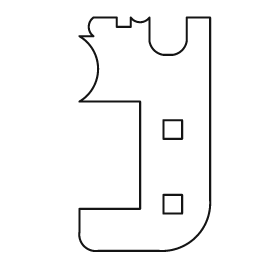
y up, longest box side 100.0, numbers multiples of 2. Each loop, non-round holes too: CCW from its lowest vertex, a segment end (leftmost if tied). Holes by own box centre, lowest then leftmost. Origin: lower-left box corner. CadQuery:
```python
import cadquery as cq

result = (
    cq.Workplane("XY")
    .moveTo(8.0, 0.0)
    .lineTo(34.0, 0.0)
    .threePointArc((50.0, 6.0), (56.0, 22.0))
    .lineTo(56.0, 100.0)
    .lineTo(46.0, 100.0)
    .lineTo(46.0, 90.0)
    .threePointArc((44.0, 86.0), (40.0, 84.0))
    .lineTo(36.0, 84.0)
    .threePointArc((32.0, 86.0), (30.0, 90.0))
    .lineTo(30.0, 100.0)
    .threePointArc((26.0, 98.0), (22.0, 100.0))
    .lineTo(22.0, 96.0)
    .lineTo(16.0, 96.0)
    .lineTo(16.0, 100.0)
    .lineTo(6.0, 100.0)
    .threePointArc((4.0, 96.0), (6.0, 92.0))
    .lineTo(0.0, 92.0)
    .threePointArc((8.0, 78.0), (0.0, 64.0))
    .lineTo(26.0, 64.0)
    .lineTo(26.0, 18.0)
    .lineTo(0.0, 18.0)
    .lineTo(0.0, 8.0)
    .threePointArc((2.0, 2.0), (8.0, 0.0))
    .close()
    .moveTo(36.0, 16.0)
    .lineTo(44.0, 16.0)
    .lineTo(44.0, 24.0)
    .lineTo(36.0, 24.0)
    .close()
    .moveTo(36.0, 48.0)
    .lineTo(44.0, 48.0)
    .lineTo(44.0, 56.0)
    .lineTo(36.0, 56.0)
    .close()
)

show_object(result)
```